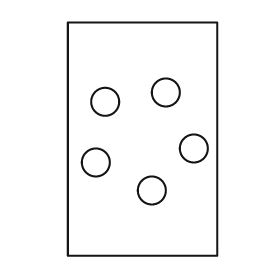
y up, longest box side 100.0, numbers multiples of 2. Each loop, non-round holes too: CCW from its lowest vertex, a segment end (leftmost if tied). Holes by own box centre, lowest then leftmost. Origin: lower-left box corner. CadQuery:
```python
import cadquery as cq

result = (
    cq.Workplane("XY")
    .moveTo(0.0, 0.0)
    .lineTo(64.0, 0.0)
    .lineTo(64.0, 100.0)
    .lineTo(0.0, 100.0)
    .close()
    .moveTo(36.0, 28.0)
    .circle(6.0)
    .moveTo(12.0, 40.0)
    .circle(6.0)
    .moveTo(54.0, 46.0)
    .circle(6.0)
    .moveTo(16.0, 66.0)
    .circle(6.0)
    .moveTo(42.0, 70.0)
    .circle(6.0)
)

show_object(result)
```